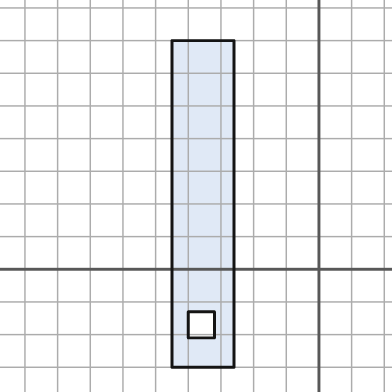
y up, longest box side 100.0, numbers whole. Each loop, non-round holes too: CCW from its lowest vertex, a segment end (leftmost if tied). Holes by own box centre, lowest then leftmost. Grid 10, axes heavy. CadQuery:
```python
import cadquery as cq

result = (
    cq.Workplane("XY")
    .moveTo(-45.0, -30.0)
    .lineTo(-26.0, -30.0)
    .lineTo(-26.0, 70.0)
    .lineTo(-45.0, 70.0)
    .close()
    .moveTo(-40.0, -21.0)
    .lineTo(-32.0, -21.0)
    .lineTo(-32.0, -13.0)
    .lineTo(-40.0, -13.0)
    .close()
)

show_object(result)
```